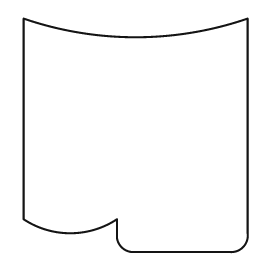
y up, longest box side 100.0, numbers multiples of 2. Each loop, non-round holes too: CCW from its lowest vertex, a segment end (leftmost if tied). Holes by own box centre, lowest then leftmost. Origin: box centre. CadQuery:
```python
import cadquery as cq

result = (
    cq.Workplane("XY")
    .moveTo(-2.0, -50.0)
    .lineTo(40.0, -50.0)
    .threePointArc((46.0, -48.0), (48.0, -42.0))
    .lineTo(48.0, 50.0)
    .threePointArc((0.0, 42.0), (-48.0, 50.0))
    .lineTo(-48.0, -36.0)
    .threePointArc((-28.0, -42.0), (-8.0, -36.0))
    .lineTo(-8.0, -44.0)
    .threePointArc((-6.0, -48.0), (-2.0, -50.0))
    .close()
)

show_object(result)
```